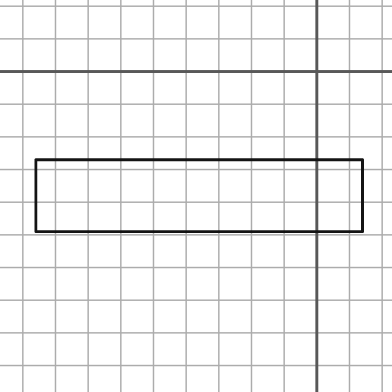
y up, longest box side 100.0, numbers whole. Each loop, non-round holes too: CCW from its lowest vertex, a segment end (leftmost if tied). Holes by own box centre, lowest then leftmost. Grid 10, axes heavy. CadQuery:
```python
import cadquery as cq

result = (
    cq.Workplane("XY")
    .moveTo(-86.0, -49.0)
    .lineTo(14.0, -49.0)
    .lineTo(14.0, -27.0)
    .lineTo(-86.0, -27.0)
    .close()
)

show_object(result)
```